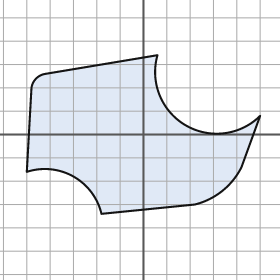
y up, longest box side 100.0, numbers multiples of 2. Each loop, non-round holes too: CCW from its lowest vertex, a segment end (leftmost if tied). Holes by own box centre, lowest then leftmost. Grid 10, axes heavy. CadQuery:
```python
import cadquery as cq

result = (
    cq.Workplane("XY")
    .moveTo(-18.0, -34.0)
    .lineTo(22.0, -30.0)
    .threePointArc((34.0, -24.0), (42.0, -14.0))
    .lineTo(50.0, 8.0)
    .threePointArc((18.0, 4.0), (6.0, 34.0))
    .lineTo(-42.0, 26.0)
    .threePointArc((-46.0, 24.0), (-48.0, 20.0))
    .lineTo(-50.0, -16.0)
    .threePointArc((-30.0, -18.0), (-18.0, -34.0))
    .close()
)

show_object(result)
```